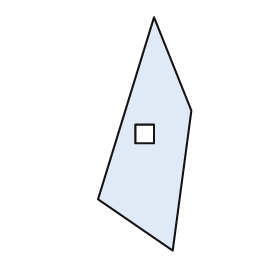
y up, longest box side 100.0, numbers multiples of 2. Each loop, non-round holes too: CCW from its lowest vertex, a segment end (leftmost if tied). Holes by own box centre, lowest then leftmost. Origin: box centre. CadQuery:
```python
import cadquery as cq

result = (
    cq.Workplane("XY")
    .moveTo(12.0, -50.0)
    .lineTo(20.0, 10.0)
    .lineTo(4.0, 50.0)
    .lineTo(-20.0, -28.0)
    .close()
    .moveTo(-4.0, -4.0)
    .lineTo(4.0, -4.0)
    .lineTo(4.0, 4.0)
    .lineTo(-4.0, 4.0)
    .close()
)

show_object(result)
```